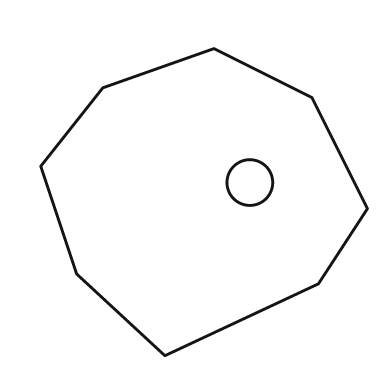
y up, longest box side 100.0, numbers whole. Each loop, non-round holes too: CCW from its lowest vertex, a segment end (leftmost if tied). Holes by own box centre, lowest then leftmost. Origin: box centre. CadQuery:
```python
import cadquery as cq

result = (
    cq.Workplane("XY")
    .moveTo(-12.0, -47.0)
    .lineTo(35.0, -25.0)
    .lineTo(50.0, -2.0)
    .lineTo(33.0, 32.0)
    .lineTo(3.0, 47.0)
    .lineTo(-31.0, 35.0)
    .lineTo(-50.0, 11.0)
    .lineTo(-39.0, -22.0)
    .close()
    .moveTo(14.0, 6.0)
    .circle(7.0)
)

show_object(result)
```